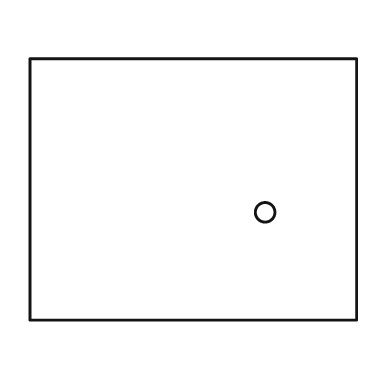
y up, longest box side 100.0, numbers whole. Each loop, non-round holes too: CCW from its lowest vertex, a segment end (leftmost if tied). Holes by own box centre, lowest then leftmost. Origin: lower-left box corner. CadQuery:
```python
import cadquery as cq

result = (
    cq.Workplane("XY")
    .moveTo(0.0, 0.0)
    .lineTo(100.0, 0.0)
    .lineTo(100.0, 80.0)
    .lineTo(0.0, 80.0)
    .close()
    .moveTo(72.0, 33.0)
    .circle(3.0)
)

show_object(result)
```